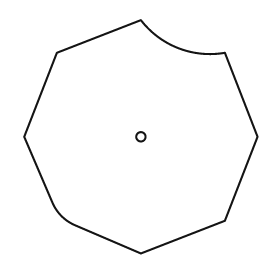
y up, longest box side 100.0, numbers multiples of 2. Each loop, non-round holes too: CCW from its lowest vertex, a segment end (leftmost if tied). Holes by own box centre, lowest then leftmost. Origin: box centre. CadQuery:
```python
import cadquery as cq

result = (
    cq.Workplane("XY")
    .moveTo(0.0, -50.0)
    .lineTo(36.0, -36.0)
    .lineTo(50.0, 0.0)
    .lineTo(36.0, 36.0)
    .threePointArc((16.0, 38.0), (0.0, 50.0))
    .lineTo(-36.0, 36.0)
    .lineTo(-50.0, 0.0)
    .lineTo(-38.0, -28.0)
    .threePointArc((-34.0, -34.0), (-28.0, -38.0))
    .close()
    .moveTo(0.0, 0.0)
    .circle(2.0)
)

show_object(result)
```